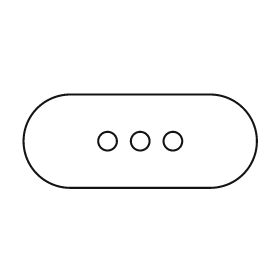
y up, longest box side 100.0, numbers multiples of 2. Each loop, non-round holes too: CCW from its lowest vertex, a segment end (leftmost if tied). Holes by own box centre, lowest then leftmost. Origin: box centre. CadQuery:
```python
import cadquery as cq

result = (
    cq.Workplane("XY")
    .moveTo(-30.0, -20.0)
    .lineTo(30.0, -20.0)
    .threePointArc((50.0, 0.0), (30.0, 20.0))
    .lineTo(-30.0, 20.0)
    .threePointArc((-50.0, 0.0), (-30.0, -20.0))
    .close()
    .moveTo(-14.0, 0.0)
    .circle(4.0)
    .moveTo(0.0, 0.0)
    .circle(4.0)
    .moveTo(14.0, 0.0)
    .circle(4.0)
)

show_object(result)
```